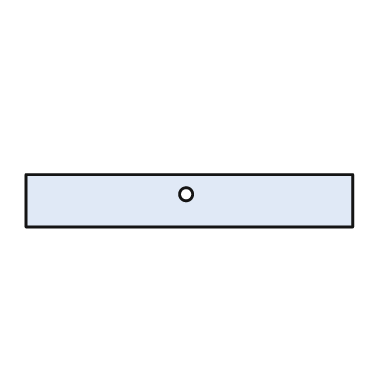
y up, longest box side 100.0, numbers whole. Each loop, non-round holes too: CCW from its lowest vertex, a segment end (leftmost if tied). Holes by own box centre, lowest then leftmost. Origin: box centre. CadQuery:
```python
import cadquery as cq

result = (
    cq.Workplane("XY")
    .moveTo(-50.0, -8.0)
    .lineTo(50.0, -8.0)
    .lineTo(50.0, 8.0)
    .lineTo(-50.0, 8.0)
    .close()
    .moveTo(-1.0, 2.0)
    .circle(2.0)
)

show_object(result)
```